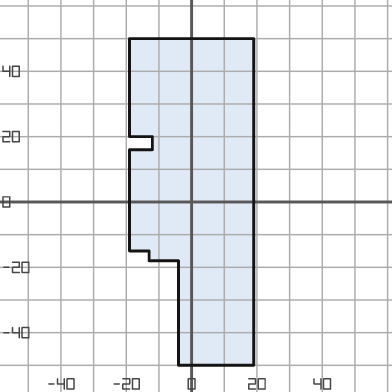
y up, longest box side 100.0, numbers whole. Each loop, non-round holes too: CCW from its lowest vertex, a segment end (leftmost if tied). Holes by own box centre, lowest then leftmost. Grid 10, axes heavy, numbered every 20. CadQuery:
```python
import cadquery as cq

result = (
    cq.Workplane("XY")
    .moveTo(-4.0, -50.0)
    .lineTo(19.0, -50.0)
    .lineTo(19.0, 50.0)
    .lineTo(-19.0, 50.0)
    .lineTo(-19.0, 20.0)
    .lineTo(-12.0, 20.0)
    .lineTo(-12.0, 16.0)
    .lineTo(-19.0, 16.0)
    .lineTo(-19.0, -15.0)
    .lineTo(-13.0, -15.0)
    .lineTo(-13.0, -18.0)
    .lineTo(-4.0, -18.0)
    .close()
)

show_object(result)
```